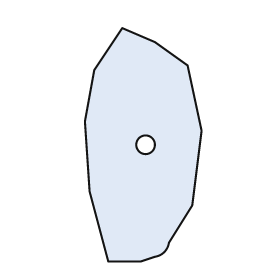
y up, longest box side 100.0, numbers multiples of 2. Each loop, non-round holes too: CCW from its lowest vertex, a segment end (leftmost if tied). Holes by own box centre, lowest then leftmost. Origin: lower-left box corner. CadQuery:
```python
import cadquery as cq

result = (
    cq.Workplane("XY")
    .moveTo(10.0, 0.0)
    .lineTo(24.0, 0.0)
    .lineTo(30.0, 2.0)
    .threePointArc((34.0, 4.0), (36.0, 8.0))
    .lineTo(46.0, 24.0)
    .lineTo(50.0, 56.0)
    .lineTo(44.0, 84.0)
    .lineTo(30.0, 94.0)
    .lineTo(16.0, 100.0)
    .lineTo(4.0, 82.0)
    .lineTo(0.0, 60.0)
    .lineTo(2.0, 30.0)
    .close()
    .moveTo(26.0, 50.0)
    .circle(4.0)
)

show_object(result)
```